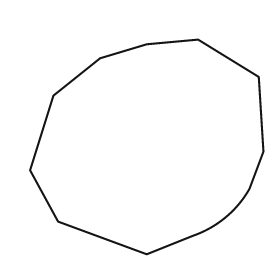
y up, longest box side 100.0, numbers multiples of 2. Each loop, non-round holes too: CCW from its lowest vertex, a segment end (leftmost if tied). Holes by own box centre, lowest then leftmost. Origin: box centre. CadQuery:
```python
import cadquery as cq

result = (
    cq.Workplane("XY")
    .moveTo(0.0, -46.0)
    .lineTo(20.0, -38.0)
    .threePointArc((34.0, -30.0), (44.0, -18.0))
    .lineTo(50.0, -2.0)
    .lineTo(48.0, 30.0)
    .lineTo(22.0, 46.0)
    .lineTo(0.0, 44.0)
    .lineTo(-20.0, 38.0)
    .lineTo(-40.0, 22.0)
    .lineTo(-50.0, -10.0)
    .lineTo(-38.0, -32.0)
    .close()
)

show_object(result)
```